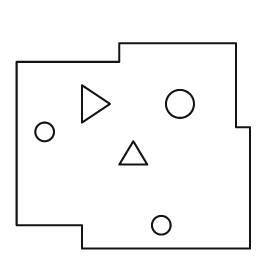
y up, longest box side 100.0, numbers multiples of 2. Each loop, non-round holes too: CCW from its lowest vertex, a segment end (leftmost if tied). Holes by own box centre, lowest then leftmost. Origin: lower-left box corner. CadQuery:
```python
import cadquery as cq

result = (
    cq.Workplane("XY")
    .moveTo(28.0, 0.0)
    .lineTo(100.0, 0.0)
    .lineTo(100.0, 52.0)
    .lineTo(94.0, 52.0)
    .lineTo(94.0, 88.0)
    .lineTo(44.0, 88.0)
    .lineTo(44.0, 80.0)
    .lineTo(0.0, 80.0)
    .lineTo(0.0, 10.0)
    .lineTo(28.0, 10.0)
    .close()
    .moveTo(62.0, 10.0)
    .circle(4.0)
    .moveTo(44.0, 36.0)
    .lineTo(56.0, 36.0)
    .lineTo(50.0, 46.0)
    .close()
    .moveTo(12.0, 50.0)
    .circle(4.0)
    .moveTo(28.0, 54.0)
    .lineTo(40.0, 62.0)
    .lineTo(28.0, 70.0)
    .close()
    .moveTo(70.0, 62.0)
    .circle(6.0)
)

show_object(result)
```